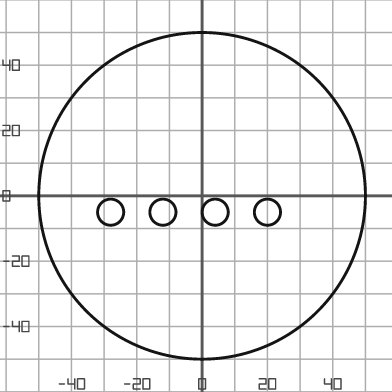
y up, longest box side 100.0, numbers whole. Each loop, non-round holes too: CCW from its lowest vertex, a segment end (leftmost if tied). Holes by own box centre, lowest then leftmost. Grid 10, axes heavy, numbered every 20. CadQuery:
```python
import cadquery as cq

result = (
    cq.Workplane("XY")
    .moveTo(0.0, 0.0)
    .circle(50.0)
    .moveTo(-28.0, -5.0)
    .circle(4.0)
    .moveTo(-12.0, -5.0)
    .circle(4.0)
    .moveTo(4.0, -5.0)
    .circle(4.0)
    .moveTo(20.0, -5.0)
    .circle(4.0)
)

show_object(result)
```